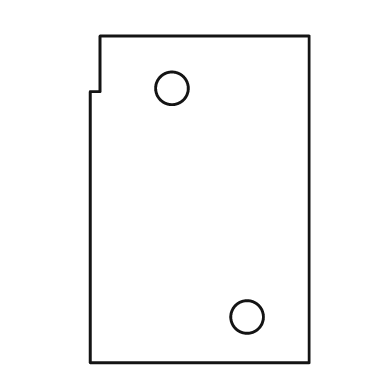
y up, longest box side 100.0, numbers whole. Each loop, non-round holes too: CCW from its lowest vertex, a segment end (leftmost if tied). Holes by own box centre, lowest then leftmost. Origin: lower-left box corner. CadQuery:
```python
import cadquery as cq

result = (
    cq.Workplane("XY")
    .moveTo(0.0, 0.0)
    .lineTo(67.0, 0.0)
    .lineTo(67.0, 100.0)
    .lineTo(3.0, 100.0)
    .lineTo(3.0, 83.0)
    .lineTo(0.0, 83.0)
    .close()
    .moveTo(48.0, 14.0)
    .circle(5.0)
    .moveTo(25.0, 84.0)
    .circle(5.0)
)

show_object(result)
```